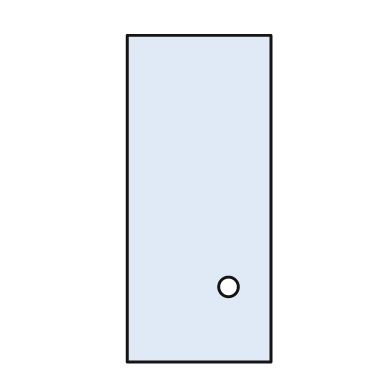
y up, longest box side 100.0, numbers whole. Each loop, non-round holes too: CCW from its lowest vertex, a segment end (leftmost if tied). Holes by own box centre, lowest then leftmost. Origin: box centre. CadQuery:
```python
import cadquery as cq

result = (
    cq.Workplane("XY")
    .moveTo(-22.0, -50.0)
    .lineTo(22.0, -50.0)
    .lineTo(22.0, 50.0)
    .lineTo(-22.0, 50.0)
    .close()
    .moveTo(9.0, -27.0)
    .circle(3.0)
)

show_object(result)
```